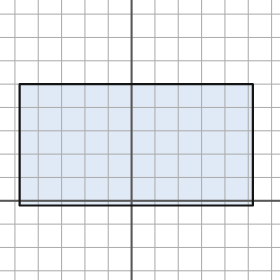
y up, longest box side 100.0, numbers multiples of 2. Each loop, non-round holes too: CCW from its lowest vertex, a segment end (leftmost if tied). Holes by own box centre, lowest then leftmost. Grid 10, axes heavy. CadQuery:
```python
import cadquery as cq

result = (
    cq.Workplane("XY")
    .moveTo(-48.0, -2.0)
    .lineTo(52.0, -2.0)
    .lineTo(52.0, 50.0)
    .lineTo(-48.0, 50.0)
    .close()
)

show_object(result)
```